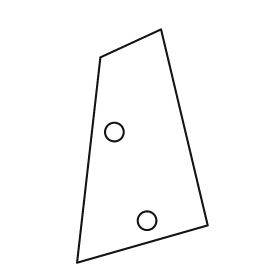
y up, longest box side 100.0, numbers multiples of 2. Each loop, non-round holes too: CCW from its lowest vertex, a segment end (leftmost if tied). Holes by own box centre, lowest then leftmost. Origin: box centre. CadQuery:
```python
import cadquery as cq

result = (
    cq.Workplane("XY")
    .moveTo(-28.0, -50.0)
    .lineTo(28.0, -34.0)
    .lineTo(8.0, 50.0)
    .lineTo(-18.0, 38.0)
    .close()
    .moveTo(2.0, -32.0)
    .circle(4.0)
    .moveTo(-12.0, 6.0)
    .circle(4.0)
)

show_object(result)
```